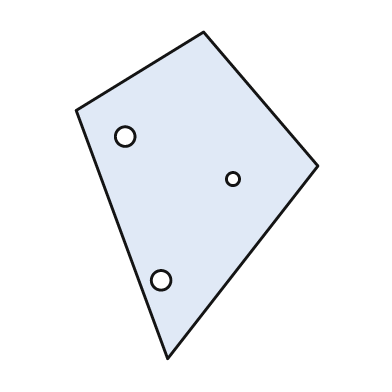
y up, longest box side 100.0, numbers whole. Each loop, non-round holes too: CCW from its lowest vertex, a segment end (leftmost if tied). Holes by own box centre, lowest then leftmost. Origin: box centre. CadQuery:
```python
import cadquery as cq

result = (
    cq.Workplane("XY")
    .moveTo(-9.0, -50.0)
    .lineTo(37.0, 9.0)
    .lineTo(2.0, 50.0)
    .lineTo(-37.0, 26.0)
    .close()
    .moveTo(-11.0, -26.0)
    .circle(3.0)
    .moveTo(11.0, 5.0)
    .circle(2.0)
    .moveTo(-22.0, 18.0)
    .circle(3.0)
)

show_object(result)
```